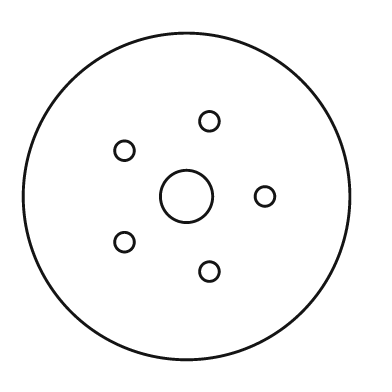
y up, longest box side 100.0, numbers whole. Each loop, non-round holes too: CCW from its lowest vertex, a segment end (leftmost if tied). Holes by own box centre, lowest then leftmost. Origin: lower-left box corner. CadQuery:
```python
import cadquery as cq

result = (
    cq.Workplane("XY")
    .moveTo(50.0, 50.0)
    .circle(50.0)
    .moveTo(57.0, 27.0)
    .circle(3.0)
    .moveTo(31.0, 36.0)
    .circle(3.0)
    .moveTo(50.0, 50.0)
    .circle(8.0)
    .moveTo(74.0, 50.0)
    .circle(3.0)
    .moveTo(31.0, 64.0)
    .circle(3.0)
    .moveTo(57.0, 73.0)
    .circle(3.0)
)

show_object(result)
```